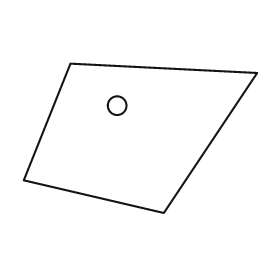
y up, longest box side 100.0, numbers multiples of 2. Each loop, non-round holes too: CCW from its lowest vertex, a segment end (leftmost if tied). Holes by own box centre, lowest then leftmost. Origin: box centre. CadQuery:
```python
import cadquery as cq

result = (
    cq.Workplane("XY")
    .moveTo(10.0, -32.0)
    .lineTo(50.0, 28.0)
    .lineTo(-30.0, 32.0)
    .lineTo(-50.0, -18.0)
    .close()
    .moveTo(-10.0, 14.0)
    .circle(4.0)
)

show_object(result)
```